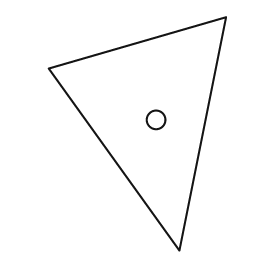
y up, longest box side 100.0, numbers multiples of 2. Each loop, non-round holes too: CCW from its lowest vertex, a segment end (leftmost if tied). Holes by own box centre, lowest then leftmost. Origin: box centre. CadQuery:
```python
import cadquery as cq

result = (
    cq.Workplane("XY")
    .moveTo(18.0, -50.0)
    .lineTo(38.0, 50.0)
    .lineTo(-38.0, 28.0)
    .close()
    .moveTo(8.0, 6.0)
    .circle(4.0)
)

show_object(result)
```